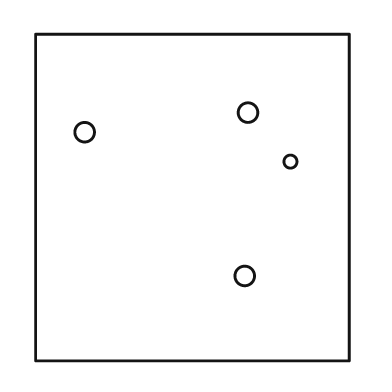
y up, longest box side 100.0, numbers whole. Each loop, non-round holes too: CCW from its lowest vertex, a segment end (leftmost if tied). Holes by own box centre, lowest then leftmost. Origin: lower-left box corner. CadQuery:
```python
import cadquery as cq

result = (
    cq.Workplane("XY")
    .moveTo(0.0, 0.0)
    .lineTo(96.0, 0.0)
    .lineTo(96.0, 100.0)
    .lineTo(0.0, 100.0)
    .close()
    .moveTo(64.0, 26.0)
    .circle(3.0)
    .moveTo(78.0, 61.0)
    .circle(2.0)
    .moveTo(15.0, 70.0)
    .circle(3.0)
    .moveTo(65.0, 76.0)
    .circle(3.0)
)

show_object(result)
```